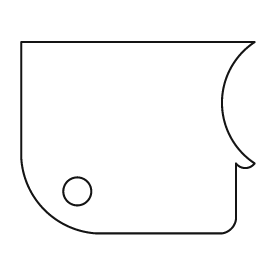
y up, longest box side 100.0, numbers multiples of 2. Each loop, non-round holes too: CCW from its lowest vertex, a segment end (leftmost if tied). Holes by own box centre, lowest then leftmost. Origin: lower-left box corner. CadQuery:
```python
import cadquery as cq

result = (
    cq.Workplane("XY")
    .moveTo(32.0, 0.0)
    .lineTo(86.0, 0.0)
    .threePointArc((90.0, 2.0), (92.0, 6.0))
    .lineTo(92.0, 30.0)
    .threePointArc((96.0, 28.0), (100.0, 30.0))
    .threePointArc((86.0, 56.0), (100.0, 82.0))
    .lineTo(0.0, 82.0)
    .lineTo(0.0, 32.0)
    .threePointArc((10.0, 10.0), (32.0, 0.0))
    .close()
    .moveTo(24.0, 18.0)
    .circle(6.0)
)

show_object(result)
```